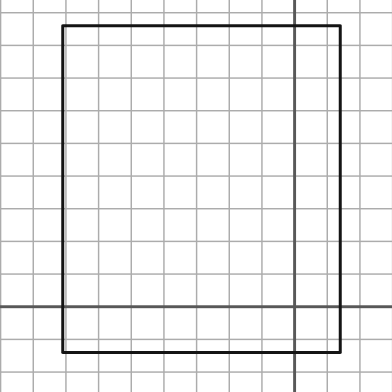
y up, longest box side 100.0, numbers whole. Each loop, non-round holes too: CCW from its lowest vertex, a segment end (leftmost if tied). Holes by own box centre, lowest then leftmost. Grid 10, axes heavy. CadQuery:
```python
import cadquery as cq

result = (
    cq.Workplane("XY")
    .moveTo(-71.0, -14.0)
    .lineTo(14.0, -14.0)
    .lineTo(14.0, 86.0)
    .lineTo(-71.0, 86.0)
    .close()
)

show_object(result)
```